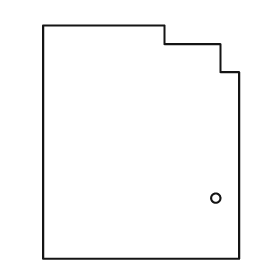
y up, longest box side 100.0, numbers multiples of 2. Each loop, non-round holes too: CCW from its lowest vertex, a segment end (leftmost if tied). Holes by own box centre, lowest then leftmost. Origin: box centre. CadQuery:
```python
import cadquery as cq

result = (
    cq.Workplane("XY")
    .moveTo(-42.0, -50.0)
    .lineTo(42.0, -50.0)
    .lineTo(42.0, 30.0)
    .lineTo(34.0, 30.0)
    .lineTo(34.0, 42.0)
    .lineTo(10.0, 42.0)
    .lineTo(10.0, 50.0)
    .lineTo(-42.0, 50.0)
    .close()
    .moveTo(32.0, -24.0)
    .circle(2.0)
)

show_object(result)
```